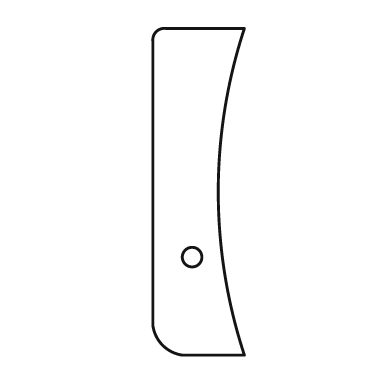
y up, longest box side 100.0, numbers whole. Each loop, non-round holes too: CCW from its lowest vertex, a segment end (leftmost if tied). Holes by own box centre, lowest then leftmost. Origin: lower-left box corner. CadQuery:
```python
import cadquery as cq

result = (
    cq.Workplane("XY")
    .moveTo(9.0, 0.0)
    .lineTo(28.0, 0.0)
    .threePointArc((20.0, 50.0), (28.0, 100.0))
    .lineTo(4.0, 100.0)
    .threePointArc((1.0, 99.0), (0.0, 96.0))
    .lineTo(0.0, 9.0)
    .threePointArc((3.0, 3.0), (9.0, 0.0))
    .close()
    .moveTo(12.0, 30.0)
    .circle(3.0)
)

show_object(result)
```